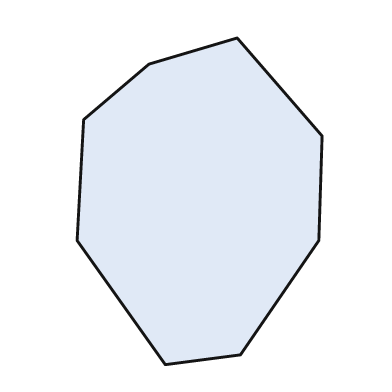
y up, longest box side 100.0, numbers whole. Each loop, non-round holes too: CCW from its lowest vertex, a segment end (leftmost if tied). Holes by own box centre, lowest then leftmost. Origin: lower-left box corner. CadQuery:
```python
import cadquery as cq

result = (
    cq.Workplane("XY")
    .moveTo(27.0, 0.0)
    .lineTo(50.0, 3.0)
    .lineTo(74.0, 38.0)
    .lineTo(75.0, 70.0)
    .lineTo(49.0, 100.0)
    .lineTo(22.0, 92.0)
    .lineTo(2.0, 75.0)
    .lineTo(0.0, 38.0)
    .close()
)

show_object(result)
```